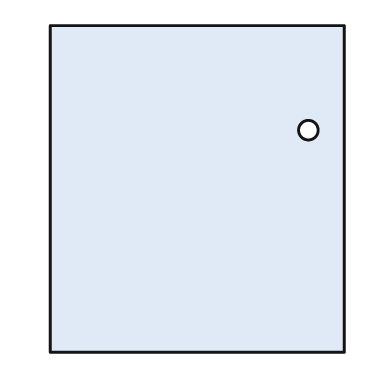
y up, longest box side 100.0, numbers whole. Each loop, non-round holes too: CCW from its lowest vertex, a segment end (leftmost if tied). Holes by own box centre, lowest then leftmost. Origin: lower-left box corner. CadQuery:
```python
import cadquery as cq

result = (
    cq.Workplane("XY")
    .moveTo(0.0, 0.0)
    .lineTo(90.0, 0.0)
    .lineTo(90.0, 100.0)
    .lineTo(0.0, 100.0)
    .close()
    .moveTo(79.0, 68.0)
    .circle(3.0)
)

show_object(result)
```